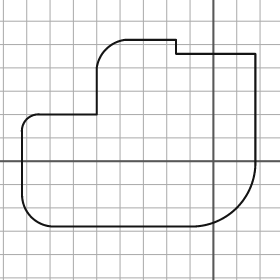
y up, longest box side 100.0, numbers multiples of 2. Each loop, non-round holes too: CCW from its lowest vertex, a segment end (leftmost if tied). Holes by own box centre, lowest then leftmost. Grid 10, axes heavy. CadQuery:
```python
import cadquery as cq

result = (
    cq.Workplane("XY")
    .moveTo(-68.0, -28.0)
    .lineTo(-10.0, -28.0)
    .threePointArc((10.0, -20.0), (18.0, 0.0))
    .lineTo(18.0, 46.0)
    .lineTo(-16.0, 46.0)
    .lineTo(-16.0, 52.0)
    .lineTo(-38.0, 52.0)
    .threePointArc((-46.0, 48.0), (-50.0, 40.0))
    .lineTo(-50.0, 20.0)
    .lineTo(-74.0, 20.0)
    .threePointArc((-80.0, 18.0), (-82.0, 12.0))
    .lineTo(-82.0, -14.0)
    .threePointArc((-78.0, -24.0), (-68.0, -28.0))
    .close()
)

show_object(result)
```